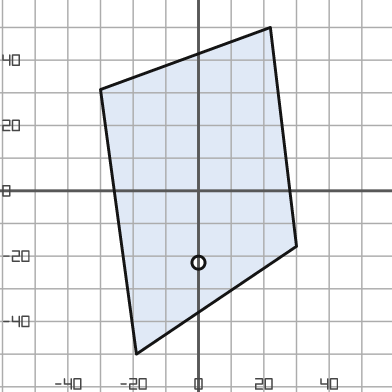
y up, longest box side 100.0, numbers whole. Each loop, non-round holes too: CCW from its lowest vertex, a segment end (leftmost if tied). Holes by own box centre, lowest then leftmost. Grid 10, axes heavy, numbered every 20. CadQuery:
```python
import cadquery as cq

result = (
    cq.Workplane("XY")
    .moveTo(-19.0, -50.0)
    .lineTo(30.0, -17.0)
    .lineTo(22.0, 50.0)
    .lineTo(-30.0, 31.0)
    .close()
    .moveTo(0.0, -22.0)
    .circle(2.0)
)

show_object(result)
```